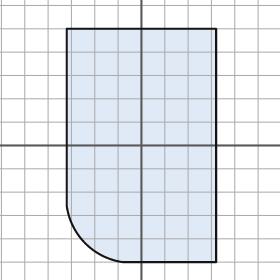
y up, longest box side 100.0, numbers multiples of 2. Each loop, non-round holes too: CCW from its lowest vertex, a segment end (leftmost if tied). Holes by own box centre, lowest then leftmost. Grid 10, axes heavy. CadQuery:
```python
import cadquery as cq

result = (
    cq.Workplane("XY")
    .moveTo(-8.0, -50.0)
    .lineTo(32.0, -50.0)
    .lineTo(32.0, 50.0)
    .lineTo(-32.0, 50.0)
    .lineTo(-32.0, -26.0)
    .threePointArc((-24.0, -42.0), (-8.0, -50.0))
    .close()
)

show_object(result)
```